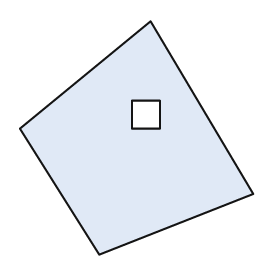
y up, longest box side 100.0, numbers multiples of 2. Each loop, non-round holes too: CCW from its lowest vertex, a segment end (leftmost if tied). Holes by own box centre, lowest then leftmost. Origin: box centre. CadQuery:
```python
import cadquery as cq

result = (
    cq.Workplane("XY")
    .moveTo(-16.0, -50.0)
    .lineTo(50.0, -24.0)
    .lineTo(6.0, 50.0)
    .lineTo(-50.0, 4.0)
    .close()
    .moveTo(-2.0, 4.0)
    .lineTo(10.0, 4.0)
    .lineTo(10.0, 16.0)
    .lineTo(-2.0, 16.0)
    .close()
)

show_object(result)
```